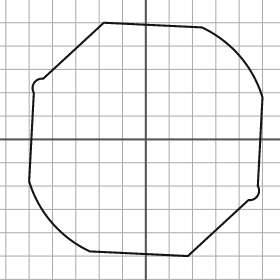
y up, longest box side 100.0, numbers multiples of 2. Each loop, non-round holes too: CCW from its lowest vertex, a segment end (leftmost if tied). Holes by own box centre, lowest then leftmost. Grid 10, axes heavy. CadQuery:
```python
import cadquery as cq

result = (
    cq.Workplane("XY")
    .moveTo(18.0, -50.0)
    .lineTo(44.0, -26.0)
    .threePointArc((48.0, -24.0), (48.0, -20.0))
    .lineTo(50.0, 18.0)
    .threePointArc((40.0, 36.0), (24.0, 48.0))
    .lineTo(-18.0, 50.0)
    .lineTo(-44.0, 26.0)
    .threePointArc((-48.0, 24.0), (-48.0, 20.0))
    .lineTo(-50.0, -18.0)
    .threePointArc((-40.0, -36.0), (-24.0, -48.0))
    .close()
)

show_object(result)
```